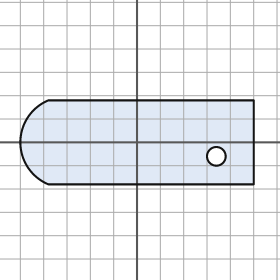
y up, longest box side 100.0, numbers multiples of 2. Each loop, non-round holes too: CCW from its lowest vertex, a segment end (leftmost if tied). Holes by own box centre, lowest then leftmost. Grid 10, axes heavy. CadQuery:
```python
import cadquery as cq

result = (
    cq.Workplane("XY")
    .moveTo(-38.0, -18.0)
    .lineTo(50.0, -18.0)
    .lineTo(50.0, 18.0)
    .lineTo(-38.0, 18.0)
    .threePointArc((-50.0, 0.0), (-38.0, -18.0))
    .close()
    .moveTo(34.0, -6.0)
    .circle(4.0)
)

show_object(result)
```